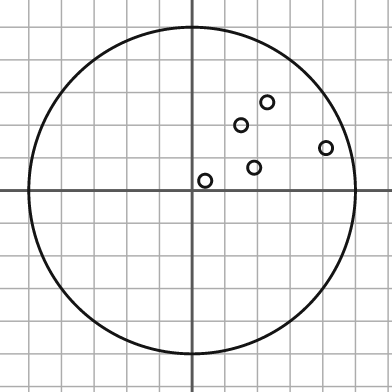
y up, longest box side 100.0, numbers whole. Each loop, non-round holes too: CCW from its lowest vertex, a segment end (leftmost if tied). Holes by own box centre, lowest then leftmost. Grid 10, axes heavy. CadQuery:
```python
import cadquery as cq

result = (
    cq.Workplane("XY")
    .moveTo(0.0, 0.0)
    .circle(50.0)
    .moveTo(4.0, 3.0)
    .circle(2.0)
    .moveTo(19.0, 7.0)
    .circle(2.0)
    .moveTo(41.0, 13.0)
    .circle(2.0)
    .moveTo(15.0, 20.0)
    .circle(2.0)
    .moveTo(23.0, 27.0)
    .circle(2.0)
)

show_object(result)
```